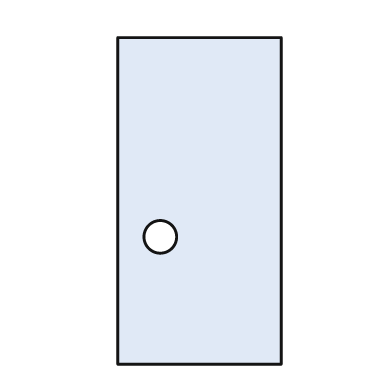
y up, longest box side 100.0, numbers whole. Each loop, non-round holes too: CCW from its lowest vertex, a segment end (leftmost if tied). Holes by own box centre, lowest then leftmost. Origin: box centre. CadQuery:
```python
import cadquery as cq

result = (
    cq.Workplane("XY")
    .moveTo(-25.0, -50.0)
    .lineTo(25.0, -50.0)
    .lineTo(25.0, 50.0)
    .lineTo(-25.0, 50.0)
    .close()
    .moveTo(-12.0, -11.0)
    .circle(5.0)
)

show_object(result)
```